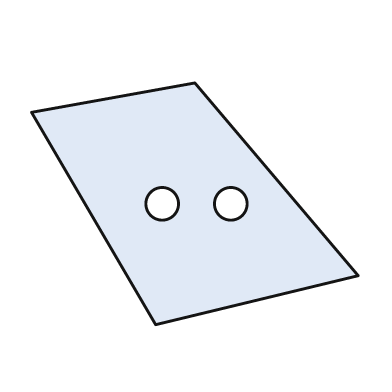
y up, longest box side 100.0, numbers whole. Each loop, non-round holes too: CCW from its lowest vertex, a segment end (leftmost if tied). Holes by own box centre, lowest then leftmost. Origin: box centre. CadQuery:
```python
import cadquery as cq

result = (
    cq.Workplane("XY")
    .moveTo(-12.0, -37.0)
    .lineTo(50.0, -22.0)
    .lineTo(0.0, 37.0)
    .lineTo(-50.0, 28.0)
    .close()
    .moveTo(-10.0, 0.0)
    .circle(5.0)
    .moveTo(11.0, 0.0)
    .circle(5.0)
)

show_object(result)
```